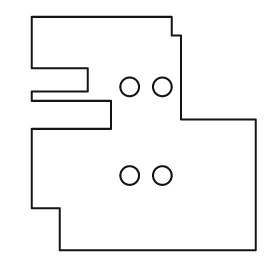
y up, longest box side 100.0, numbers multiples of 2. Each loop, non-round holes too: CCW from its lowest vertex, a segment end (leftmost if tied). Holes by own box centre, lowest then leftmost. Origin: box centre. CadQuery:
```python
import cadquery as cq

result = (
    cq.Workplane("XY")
    .moveTo(-36.0, -50.0)
    .lineTo(48.0, -50.0)
    .lineTo(48.0, 6.0)
    .lineTo(16.0, 6.0)
    .lineTo(16.0, 42.0)
    .lineTo(12.0, 42.0)
    .lineTo(12.0, 50.0)
    .lineTo(-48.0, 50.0)
    .lineTo(-48.0, 28.0)
    .lineTo(-24.0, 28.0)
    .lineTo(-24.0, 18.0)
    .lineTo(-48.0, 18.0)
    .lineTo(-48.0, 14.0)
    .lineTo(-14.0, 14.0)
    .lineTo(-14.0, 2.0)
    .lineTo(-48.0, 2.0)
    .lineTo(-48.0, -32.0)
    .lineTo(-36.0, -32.0)
    .close()
    .moveTo(-6.0, -18.0)
    .circle(4.0)
    .moveTo(8.0, -18.0)
    .circle(4.0)
    .moveTo(-6.0, 20.0)
    .circle(4.0)
    .moveTo(8.0, 20.0)
    .circle(4.0)
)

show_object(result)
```